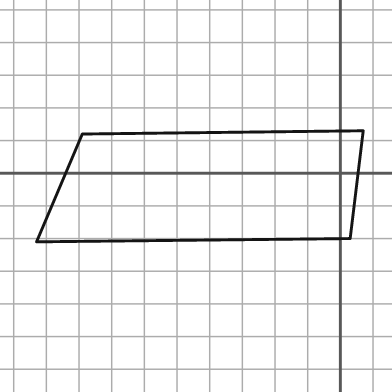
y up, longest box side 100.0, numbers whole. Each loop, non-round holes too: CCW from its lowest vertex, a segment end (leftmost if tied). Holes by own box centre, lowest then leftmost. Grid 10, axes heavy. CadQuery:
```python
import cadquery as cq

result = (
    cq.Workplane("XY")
    .moveTo(-93.0, -21.0)
    .lineTo(3.0, -20.0)
    .lineTo(7.0, 13.0)
    .lineTo(-79.0, 12.0)
    .close()
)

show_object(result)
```